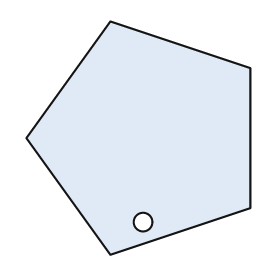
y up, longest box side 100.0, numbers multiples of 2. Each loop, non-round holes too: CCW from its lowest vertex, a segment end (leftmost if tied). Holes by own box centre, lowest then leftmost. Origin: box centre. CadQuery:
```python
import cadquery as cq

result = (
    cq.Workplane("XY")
    .moveTo(-12.0, -50.0)
    .lineTo(48.0, -30.0)
    .lineTo(48.0, 30.0)
    .lineTo(-12.0, 50.0)
    .lineTo(-48.0, 0.0)
    .close()
    .moveTo(2.0, -36.0)
    .circle(4.0)
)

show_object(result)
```